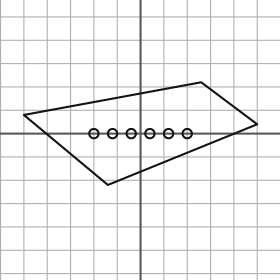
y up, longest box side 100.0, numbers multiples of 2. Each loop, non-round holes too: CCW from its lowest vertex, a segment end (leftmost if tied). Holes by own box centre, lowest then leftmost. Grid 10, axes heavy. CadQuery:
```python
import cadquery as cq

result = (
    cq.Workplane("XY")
    .moveTo(-14.0, -22.0)
    .lineTo(50.0, 4.0)
    .lineTo(26.0, 22.0)
    .lineTo(-50.0, 8.0)
    .close()
    .moveTo(-20.0, 0.0)
    .circle(2.0)
    .moveTo(-12.0, 0.0)
    .circle(2.0)
    .moveTo(-4.0, 0.0)
    .circle(2.0)
    .moveTo(4.0, 0.0)
    .circle(2.0)
    .moveTo(12.0, 0.0)
    .circle(2.0)
    .moveTo(20.0, 0.0)
    .circle(2.0)
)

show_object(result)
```